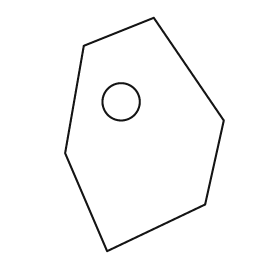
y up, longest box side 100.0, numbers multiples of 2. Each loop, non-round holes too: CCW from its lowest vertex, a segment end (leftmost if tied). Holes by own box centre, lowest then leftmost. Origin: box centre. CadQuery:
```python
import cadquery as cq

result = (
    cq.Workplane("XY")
    .moveTo(-16.0, -50.0)
    .lineTo(26.0, -30.0)
    .lineTo(34.0, 6.0)
    .lineTo(4.0, 50.0)
    .lineTo(-26.0, 38.0)
    .lineTo(-34.0, -8.0)
    .close()
    .moveTo(-10.0, 14.0)
    .circle(8.0)
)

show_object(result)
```